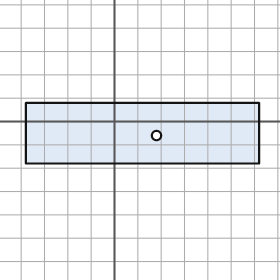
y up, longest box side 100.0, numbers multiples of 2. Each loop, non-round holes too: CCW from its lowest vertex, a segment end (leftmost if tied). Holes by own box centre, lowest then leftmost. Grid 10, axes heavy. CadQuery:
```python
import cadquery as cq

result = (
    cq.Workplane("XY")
    .moveTo(-38.0, -18.0)
    .lineTo(62.0, -18.0)
    .lineTo(62.0, 8.0)
    .lineTo(-38.0, 8.0)
    .close()
    .moveTo(18.0, -6.0)
    .circle(2.0)
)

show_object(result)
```